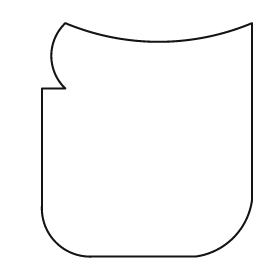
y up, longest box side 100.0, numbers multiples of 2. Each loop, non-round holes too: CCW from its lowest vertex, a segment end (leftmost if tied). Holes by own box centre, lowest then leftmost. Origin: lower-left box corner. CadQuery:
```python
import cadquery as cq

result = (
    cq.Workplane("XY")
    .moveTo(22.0, 0.0)
    .lineTo(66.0, 0.0)
    .threePointArc((82.0, 8.0), (90.0, 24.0))
    .lineTo(90.0, 100.0)
    .threePointArc((50.0, 92.0), (10.0, 100.0))
    .threePointArc((4.0, 86.0), (10.0, 72.0))
    .lineTo(0.0, 72.0)
    .lineTo(0.0, 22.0)
    .threePointArc((6.0, 6.0), (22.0, 0.0))
    .close()
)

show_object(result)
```